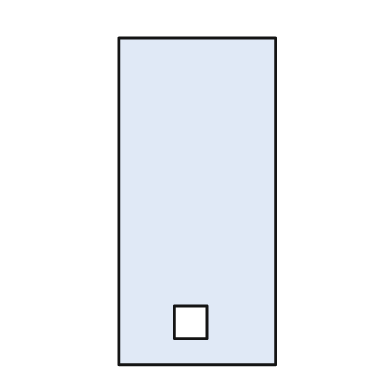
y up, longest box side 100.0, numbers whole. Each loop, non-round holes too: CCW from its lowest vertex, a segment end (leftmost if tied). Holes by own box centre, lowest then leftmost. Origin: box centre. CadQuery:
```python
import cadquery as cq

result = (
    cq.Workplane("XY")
    .moveTo(-24.0, -50.0)
    .lineTo(24.0, -50.0)
    .lineTo(24.0, 50.0)
    .lineTo(-24.0, 50.0)
    .close()
    .moveTo(-7.0, -42.0)
    .lineTo(3.0, -42.0)
    .lineTo(3.0, -32.0)
    .lineTo(-7.0, -32.0)
    .close()
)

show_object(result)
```